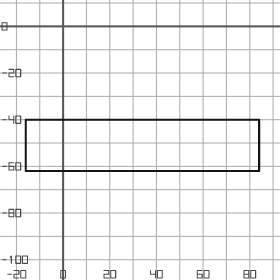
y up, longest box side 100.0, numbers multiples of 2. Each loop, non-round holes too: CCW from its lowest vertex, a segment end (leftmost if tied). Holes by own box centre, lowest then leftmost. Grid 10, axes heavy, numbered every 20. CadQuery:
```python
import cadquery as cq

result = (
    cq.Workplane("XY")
    .moveTo(-16.0, -62.0)
    .lineTo(84.0, -62.0)
    .lineTo(84.0, -40.0)
    .lineTo(-16.0, -40.0)
    .close()
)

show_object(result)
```